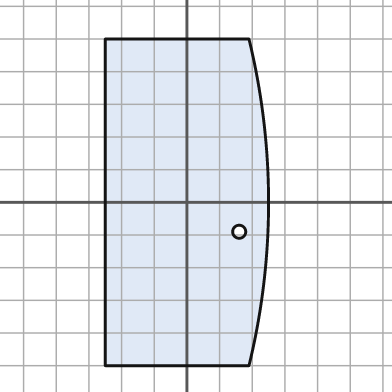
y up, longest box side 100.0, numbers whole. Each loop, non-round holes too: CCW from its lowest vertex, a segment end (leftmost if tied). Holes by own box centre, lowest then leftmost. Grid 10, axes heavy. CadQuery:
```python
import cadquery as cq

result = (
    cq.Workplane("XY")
    .moveTo(-25.0, -50.0)
    .lineTo(19.0, -50.0)
    .threePointArc((25.0, 0.0), (19.0, 50.0))
    .lineTo(-25.0, 50.0)
    .close()
    .moveTo(16.0, -9.0)
    .circle(2.0)
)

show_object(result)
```